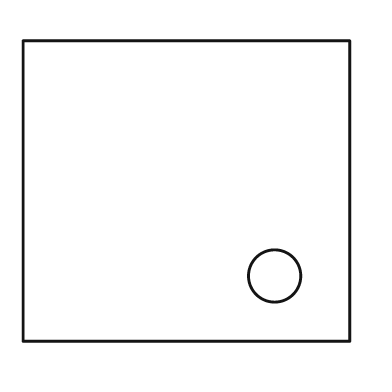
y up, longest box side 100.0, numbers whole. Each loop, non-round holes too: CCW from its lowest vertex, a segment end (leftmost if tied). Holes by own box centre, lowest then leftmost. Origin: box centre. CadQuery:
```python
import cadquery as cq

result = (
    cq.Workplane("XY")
    .moveTo(-50.0, -46.0)
    .lineTo(50.0, -46.0)
    .lineTo(50.0, 46.0)
    .lineTo(-50.0, 46.0)
    .close()
    .moveTo(27.0, -26.0)
    .circle(8.0)
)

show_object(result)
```